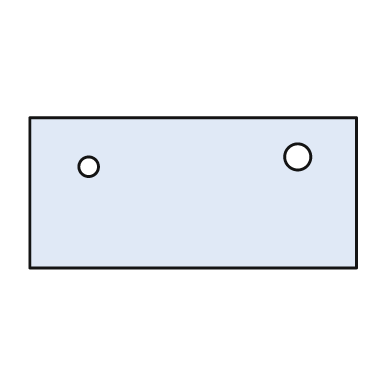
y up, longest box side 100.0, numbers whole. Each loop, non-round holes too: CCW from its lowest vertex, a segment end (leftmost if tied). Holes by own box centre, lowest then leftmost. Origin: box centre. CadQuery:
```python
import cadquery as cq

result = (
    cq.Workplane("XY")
    .moveTo(-50.0, -23.0)
    .lineTo(50.0, -23.0)
    .lineTo(50.0, 23.0)
    .lineTo(-50.0, 23.0)
    .close()
    .moveTo(-32.0, 8.0)
    .circle(3.0)
    .moveTo(32.0, 11.0)
    .circle(4.0)
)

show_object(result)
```